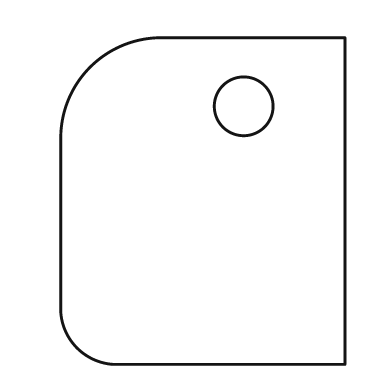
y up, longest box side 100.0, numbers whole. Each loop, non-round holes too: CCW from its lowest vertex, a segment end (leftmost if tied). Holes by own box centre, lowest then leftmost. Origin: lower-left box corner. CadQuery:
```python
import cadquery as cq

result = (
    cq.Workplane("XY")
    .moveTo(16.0, 0.0)
    .lineTo(87.0, 0.0)
    .lineTo(87.0, 100.0)
    .lineTo(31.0, 100.0)
    .threePointArc((9.0, 91.0), (0.0, 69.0))
    .lineTo(0.0, 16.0)
    .threePointArc((5.0, 5.0), (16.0, 0.0))
    .close()
    .moveTo(56.0, 79.0)
    .circle(9.0)
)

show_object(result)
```